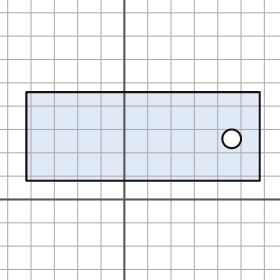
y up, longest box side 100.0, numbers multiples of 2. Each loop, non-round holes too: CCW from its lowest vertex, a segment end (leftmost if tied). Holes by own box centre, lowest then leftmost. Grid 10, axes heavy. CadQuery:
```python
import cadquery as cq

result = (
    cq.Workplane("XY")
    .moveTo(-42.0, 8.0)
    .lineTo(58.0, 8.0)
    .lineTo(58.0, 46.0)
    .lineTo(-42.0, 46.0)
    .close()
    .moveTo(46.0, 26.0)
    .circle(4.0)
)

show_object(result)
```